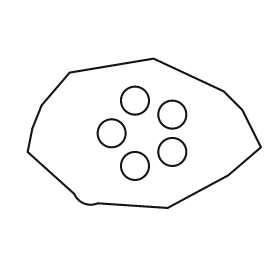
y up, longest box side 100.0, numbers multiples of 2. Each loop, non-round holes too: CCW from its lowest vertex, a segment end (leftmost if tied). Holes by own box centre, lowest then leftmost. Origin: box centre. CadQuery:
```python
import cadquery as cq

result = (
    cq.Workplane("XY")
    .moveTo(10.0, -32.0)
    .lineTo(36.0, -18.0)
    .lineTo(50.0, -6.0)
    .lineTo(42.0, 10.0)
    .lineTo(34.0, 18.0)
    .lineTo(4.0, 32.0)
    .lineTo(-32.0, 26.0)
    .lineTo(-44.0, 12.0)
    .lineTo(-48.0, 2.0)
    .lineTo(-50.0, -8.0)
    .lineTo(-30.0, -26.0)
    .threePointArc((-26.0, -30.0), (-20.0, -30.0))
    .close()
    .moveTo(-4.0, -14.0)
    .circle(6.0)
    .moveTo(12.0, -8.0)
    .circle(6.0)
    .moveTo(-14.0, 0.0)
    .circle(6.0)
    .moveTo(12.0, 8.0)
    .circle(6.0)
    .moveTo(-4.0, 14.0)
    .circle(6.0)
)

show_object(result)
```